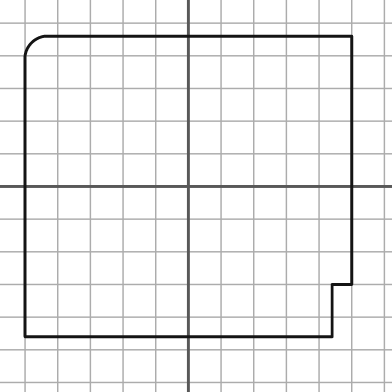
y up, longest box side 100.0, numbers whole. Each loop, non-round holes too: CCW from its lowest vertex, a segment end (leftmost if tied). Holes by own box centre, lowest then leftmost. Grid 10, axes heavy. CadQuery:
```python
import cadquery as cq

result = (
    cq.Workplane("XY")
    .moveTo(-50.0, -46.0)
    .lineTo(44.0, -46.0)
    .lineTo(44.0, -30.0)
    .lineTo(50.0, -30.0)
    .lineTo(50.0, 46.0)
    .lineTo(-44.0, 46.0)
    .threePointArc((-48.0, 44.0), (-50.0, 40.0))
    .close()
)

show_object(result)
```